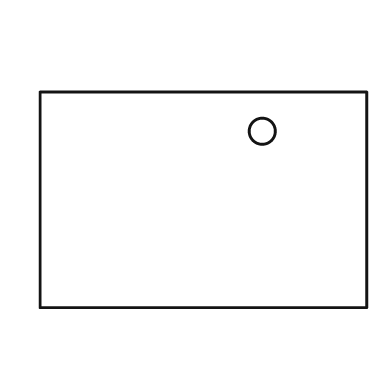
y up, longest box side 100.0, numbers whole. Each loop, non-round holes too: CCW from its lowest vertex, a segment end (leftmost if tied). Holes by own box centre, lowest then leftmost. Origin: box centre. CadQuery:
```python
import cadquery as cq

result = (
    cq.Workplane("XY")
    .moveTo(-50.0, -33.0)
    .lineTo(50.0, -33.0)
    .lineTo(50.0, 33.0)
    .lineTo(-50.0, 33.0)
    .close()
    .moveTo(18.0, 21.0)
    .circle(4.0)
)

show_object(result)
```